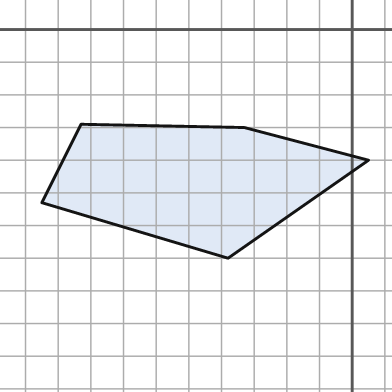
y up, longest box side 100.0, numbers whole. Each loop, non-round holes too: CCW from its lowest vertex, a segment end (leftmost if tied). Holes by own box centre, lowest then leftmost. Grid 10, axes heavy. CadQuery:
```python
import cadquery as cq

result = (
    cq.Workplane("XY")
    .moveTo(-38.0, -70.0)
    .lineTo(5.0, -40.0)
    .lineTo(-33.0, -30.0)
    .lineTo(-83.0, -29.0)
    .lineTo(-95.0, -53.0)
    .close()
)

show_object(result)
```